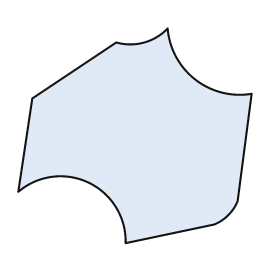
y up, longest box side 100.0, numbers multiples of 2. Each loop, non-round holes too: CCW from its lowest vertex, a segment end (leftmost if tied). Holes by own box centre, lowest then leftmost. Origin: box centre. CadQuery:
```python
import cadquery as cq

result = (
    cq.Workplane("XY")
    .moveTo(-4.0, -46.0)
    .lineTo(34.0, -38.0)
    .threePointArc((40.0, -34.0), (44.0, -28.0))
    .lineTo(50.0, 18.0)
    .threePointArc((26.0, 24.0), (14.0, 46.0))
    .threePointArc((4.0, 40.0), (-8.0, 40.0))
    .lineTo(-44.0, 16.0)
    .lineTo(-50.0, -24.0)
    .threePointArc((-20.0, -20.0), (-4.0, -46.0))
    .close()
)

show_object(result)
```